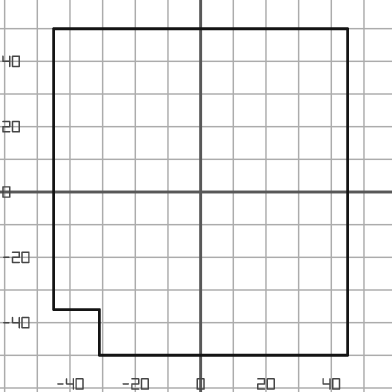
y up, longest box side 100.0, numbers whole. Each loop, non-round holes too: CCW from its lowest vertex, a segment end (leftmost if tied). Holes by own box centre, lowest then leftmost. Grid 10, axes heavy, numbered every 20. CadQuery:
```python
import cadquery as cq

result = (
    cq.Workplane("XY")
    .moveTo(-31.0, -50.0)
    .lineTo(45.0, -50.0)
    .lineTo(45.0, 50.0)
    .lineTo(-45.0, 50.0)
    .lineTo(-45.0, -36.0)
    .lineTo(-31.0, -36.0)
    .close()
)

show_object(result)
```